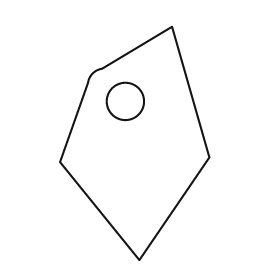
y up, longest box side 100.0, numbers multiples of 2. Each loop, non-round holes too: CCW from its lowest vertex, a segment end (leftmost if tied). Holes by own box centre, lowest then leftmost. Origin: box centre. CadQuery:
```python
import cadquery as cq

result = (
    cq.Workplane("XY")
    .moveTo(2.0, -50.0)
    .lineTo(32.0, -6.0)
    .lineTo(16.0, 50.0)
    .lineTo(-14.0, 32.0)
    .threePointArc((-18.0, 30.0), (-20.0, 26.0))
    .lineTo(-32.0, -8.0)
    .close()
    .moveTo(-4.0, 18.0)
    .circle(8.0)
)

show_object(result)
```